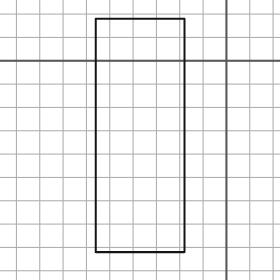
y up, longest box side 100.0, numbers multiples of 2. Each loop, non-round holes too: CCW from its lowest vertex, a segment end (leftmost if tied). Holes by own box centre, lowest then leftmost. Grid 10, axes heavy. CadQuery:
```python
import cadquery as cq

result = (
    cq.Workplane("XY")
    .moveTo(-56.0, -82.0)
    .lineTo(-18.0, -82.0)
    .lineTo(-18.0, 18.0)
    .lineTo(-56.0, 18.0)
    .close()
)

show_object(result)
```